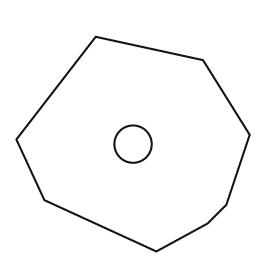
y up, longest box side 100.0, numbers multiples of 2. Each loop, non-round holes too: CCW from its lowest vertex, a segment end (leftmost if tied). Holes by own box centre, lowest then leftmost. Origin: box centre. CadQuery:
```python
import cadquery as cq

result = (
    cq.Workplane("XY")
    .moveTo(10.0, -46.0)
    .lineTo(32.0, -34.0)
    .lineTo(40.0, -26.0)
    .lineTo(50.0, 4.0)
    .lineTo(30.0, 36.0)
    .lineTo(-16.0, 46.0)
    .lineTo(-50.0, 2.0)
    .lineTo(-38.0, -24.0)
    .close()
    .moveTo(0.0, 0.0)
    .circle(8.0)
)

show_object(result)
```